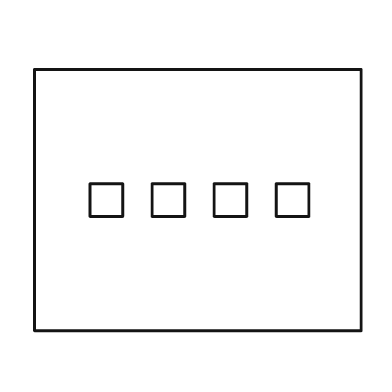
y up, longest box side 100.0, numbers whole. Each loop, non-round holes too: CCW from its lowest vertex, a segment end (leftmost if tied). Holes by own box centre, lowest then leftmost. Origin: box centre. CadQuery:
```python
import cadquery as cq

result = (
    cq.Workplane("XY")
    .moveTo(-50.0, -40.0)
    .lineTo(50.0, -40.0)
    .lineTo(50.0, 40.0)
    .lineTo(-50.0, 40.0)
    .close()
    .moveTo(-33.0, -5.0)
    .lineTo(-23.0, -5.0)
    .lineTo(-23.0, 5.0)
    .lineTo(-33.0, 5.0)
    .close()
    .moveTo(-14.0, -5.0)
    .lineTo(-4.0, -5.0)
    .lineTo(-4.0, 5.0)
    .lineTo(-14.0, 5.0)
    .close()
    .moveTo(5.0, -5.0)
    .lineTo(15.0, -5.0)
    .lineTo(15.0, 5.0)
    .lineTo(5.0, 5.0)
    .close()
    .moveTo(24.0, -5.0)
    .lineTo(34.0, -5.0)
    .lineTo(34.0, 5.0)
    .lineTo(24.0, 5.0)
    .close()
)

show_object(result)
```